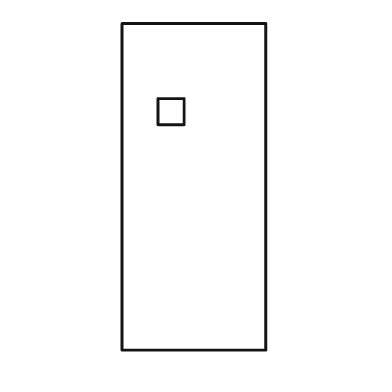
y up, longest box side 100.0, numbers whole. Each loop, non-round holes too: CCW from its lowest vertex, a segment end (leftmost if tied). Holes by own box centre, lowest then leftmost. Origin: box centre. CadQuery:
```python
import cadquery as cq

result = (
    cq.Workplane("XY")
    .moveTo(-22.0, -50.0)
    .lineTo(22.0, -50.0)
    .lineTo(22.0, 50.0)
    .lineTo(-22.0, 50.0)
    .close()
    .moveTo(-11.0, 19.0)
    .lineTo(-3.0, 19.0)
    .lineTo(-3.0, 27.0)
    .lineTo(-11.0, 27.0)
    .close()
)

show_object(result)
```